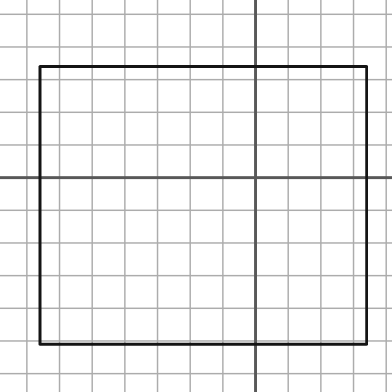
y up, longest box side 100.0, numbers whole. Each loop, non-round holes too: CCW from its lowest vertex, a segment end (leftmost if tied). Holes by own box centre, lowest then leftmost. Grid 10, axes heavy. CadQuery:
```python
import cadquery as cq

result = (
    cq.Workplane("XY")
    .moveTo(-66.0, -51.0)
    .lineTo(34.0, -51.0)
    .lineTo(34.0, 34.0)
    .lineTo(-66.0, 34.0)
    .close()
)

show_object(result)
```